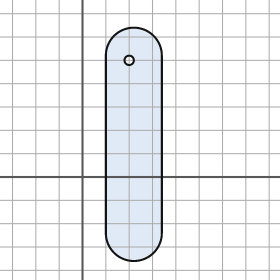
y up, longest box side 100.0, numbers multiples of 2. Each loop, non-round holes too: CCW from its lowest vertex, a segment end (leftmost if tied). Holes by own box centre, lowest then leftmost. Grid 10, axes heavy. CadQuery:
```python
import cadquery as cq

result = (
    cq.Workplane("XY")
    .moveTo(10.0, -24.0)
    .threePointArc((22.0, -36.0), (34.0, -24.0))
    .lineTo(34.0, 52.0)
    .threePointArc((22.0, 64.0), (10.0, 52.0))
    .close()
    .moveTo(20.0, 50.0)
    .circle(2.0)
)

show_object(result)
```